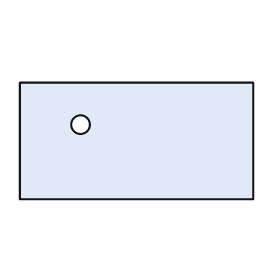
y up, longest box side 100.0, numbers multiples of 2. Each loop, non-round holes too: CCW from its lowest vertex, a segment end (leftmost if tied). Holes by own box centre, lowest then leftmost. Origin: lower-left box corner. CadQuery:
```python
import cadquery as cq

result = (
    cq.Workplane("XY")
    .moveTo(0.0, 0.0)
    .lineTo(100.0, 0.0)
    .lineTo(100.0, 50.0)
    .lineTo(0.0, 50.0)
    .close()
    .moveTo(26.0, 32.0)
    .circle(4.0)
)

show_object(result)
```